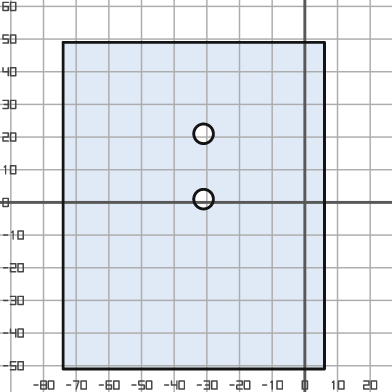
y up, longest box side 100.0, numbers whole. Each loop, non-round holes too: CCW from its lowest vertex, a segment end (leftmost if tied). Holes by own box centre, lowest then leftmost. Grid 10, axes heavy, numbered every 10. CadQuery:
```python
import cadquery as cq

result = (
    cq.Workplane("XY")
    .moveTo(-74.0, -51.0)
    .lineTo(6.0, -51.0)
    .lineTo(6.0, 49.0)
    .lineTo(-74.0, 49.0)
    .close()
    .moveTo(-31.0, 1.0)
    .circle(3.0)
    .moveTo(-31.0, 21.0)
    .circle(3.0)
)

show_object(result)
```